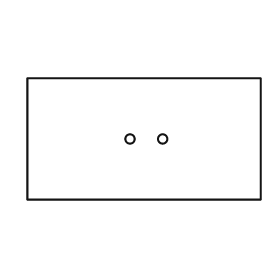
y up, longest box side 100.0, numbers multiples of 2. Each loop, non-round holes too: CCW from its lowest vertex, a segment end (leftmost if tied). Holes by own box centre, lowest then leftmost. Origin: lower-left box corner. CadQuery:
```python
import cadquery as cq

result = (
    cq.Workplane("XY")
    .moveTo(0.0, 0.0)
    .lineTo(100.0, 0.0)
    .lineTo(100.0, 52.0)
    .lineTo(0.0, 52.0)
    .close()
    .moveTo(44.0, 26.0)
    .circle(2.0)
    .moveTo(58.0, 26.0)
    .circle(2.0)
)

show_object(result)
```